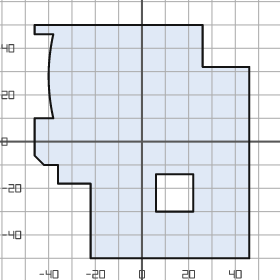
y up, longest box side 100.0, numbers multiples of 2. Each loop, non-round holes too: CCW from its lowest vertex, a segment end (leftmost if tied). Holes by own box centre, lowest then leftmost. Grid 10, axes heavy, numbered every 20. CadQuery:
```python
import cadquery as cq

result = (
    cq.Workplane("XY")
    .moveTo(-22.0, -50.0)
    .lineTo(46.0, -50.0)
    .lineTo(46.0, 32.0)
    .lineTo(26.0, 32.0)
    .lineTo(26.0, 50.0)
    .lineTo(-46.0, 50.0)
    .lineTo(-46.0, 46.0)
    .lineTo(-38.0, 46.0)
    .threePointArc((-40.0, 28.0), (-38.0, 10.0))
    .lineTo(-46.0, 10.0)
    .lineTo(-46.0, -6.0)
    .lineTo(-42.0, -10.0)
    .lineTo(-36.0, -10.0)
    .lineTo(-36.0, -18.0)
    .lineTo(-22.0, -18.0)
    .close()
    .moveTo(6.0, -30.0)
    .lineTo(22.0, -30.0)
    .lineTo(22.0, -14.0)
    .lineTo(6.0, -14.0)
    .close()
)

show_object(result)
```